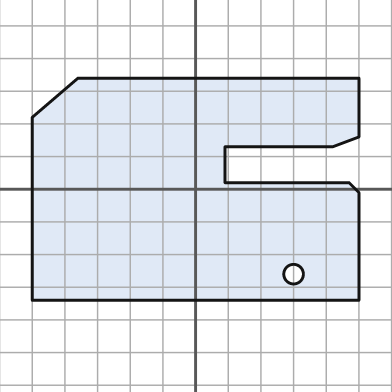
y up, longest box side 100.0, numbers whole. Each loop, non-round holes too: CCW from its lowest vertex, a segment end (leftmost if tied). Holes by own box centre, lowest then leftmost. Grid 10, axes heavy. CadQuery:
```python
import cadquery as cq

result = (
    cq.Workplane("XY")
    .moveTo(-50.0, -34.0)
    .lineTo(50.0, -34.0)
    .lineTo(50.0, -1.0)
    .lineTo(47.0, 2.0)
    .lineTo(9.0, 2.0)
    .lineTo(9.0, 13.0)
    .lineTo(42.0, 13.0)
    .lineTo(50.0, 16.0)
    .lineTo(50.0, 34.0)
    .lineTo(-36.0, 34.0)
    .lineTo(-50.0, 22.0)
    .close()
    .moveTo(30.0, -26.0)
    .circle(3.0)
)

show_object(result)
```